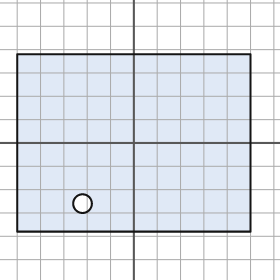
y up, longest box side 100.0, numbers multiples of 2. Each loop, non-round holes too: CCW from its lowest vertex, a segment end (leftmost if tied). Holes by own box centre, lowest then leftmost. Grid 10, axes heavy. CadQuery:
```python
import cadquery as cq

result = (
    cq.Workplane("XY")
    .moveTo(-50.0, -38.0)
    .lineTo(50.0, -38.0)
    .lineTo(50.0, 38.0)
    .lineTo(-50.0, 38.0)
    .close()
    .moveTo(-22.0, -26.0)
    .circle(4.0)
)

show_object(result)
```